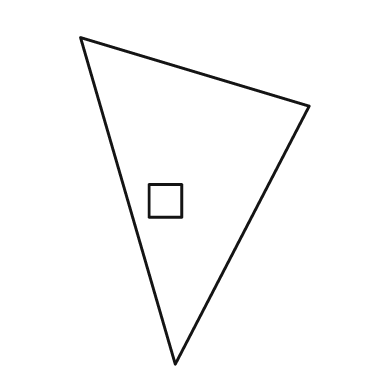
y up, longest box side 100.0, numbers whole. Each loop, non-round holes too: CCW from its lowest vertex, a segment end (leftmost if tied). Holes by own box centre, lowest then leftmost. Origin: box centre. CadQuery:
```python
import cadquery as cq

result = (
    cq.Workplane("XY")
    .moveTo(-6.0, -50.0)
    .lineTo(35.0, 29.0)
    .lineTo(-35.0, 50.0)
    .close()
    .moveTo(-14.0, -5.0)
    .lineTo(-4.0, -5.0)
    .lineTo(-4.0, 5.0)
    .lineTo(-14.0, 5.0)
    .close()
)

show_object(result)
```